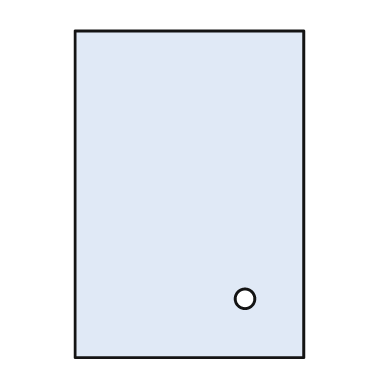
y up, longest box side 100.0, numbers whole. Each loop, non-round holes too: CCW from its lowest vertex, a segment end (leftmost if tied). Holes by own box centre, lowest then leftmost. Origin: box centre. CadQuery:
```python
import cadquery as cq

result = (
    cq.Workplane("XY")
    .moveTo(-35.0, -50.0)
    .lineTo(35.0, -50.0)
    .lineTo(35.0, 50.0)
    .lineTo(-35.0, 50.0)
    .close()
    .moveTo(17.0, -32.0)
    .circle(3.0)
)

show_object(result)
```